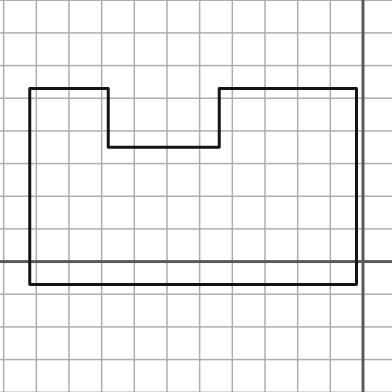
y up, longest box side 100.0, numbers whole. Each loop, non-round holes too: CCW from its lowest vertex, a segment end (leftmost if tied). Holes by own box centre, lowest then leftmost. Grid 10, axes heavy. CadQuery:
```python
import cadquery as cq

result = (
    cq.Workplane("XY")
    .moveTo(-102.0, -7.0)
    .lineTo(-2.0, -7.0)
    .lineTo(-2.0, 53.0)
    .lineTo(-44.0, 53.0)
    .lineTo(-44.0, 35.0)
    .lineTo(-78.0, 35.0)
    .lineTo(-78.0, 53.0)
    .lineTo(-102.0, 53.0)
    .close()
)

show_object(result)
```